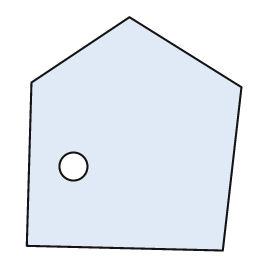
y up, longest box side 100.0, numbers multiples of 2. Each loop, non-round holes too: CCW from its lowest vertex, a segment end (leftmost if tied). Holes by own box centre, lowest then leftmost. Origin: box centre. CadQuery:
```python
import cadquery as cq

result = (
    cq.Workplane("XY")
    .moveTo(38.0, -50.0)
    .lineTo(46.0, 20.0)
    .lineTo(-2.0, 50.0)
    .lineTo(-44.0, 22.0)
    .lineTo(-46.0, -48.0)
    .close()
    .moveTo(-26.0, -14.0)
    .circle(6.0)
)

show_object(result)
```